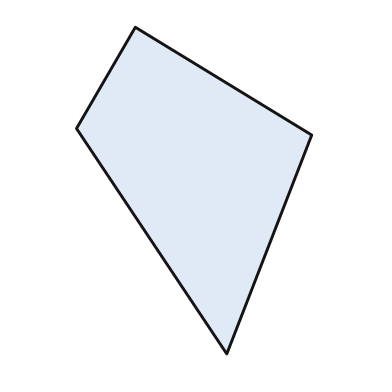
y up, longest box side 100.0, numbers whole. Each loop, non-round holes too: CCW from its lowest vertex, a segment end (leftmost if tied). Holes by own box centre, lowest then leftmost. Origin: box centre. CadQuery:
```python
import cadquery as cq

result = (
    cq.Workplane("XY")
    .moveTo(10.0, -50.0)
    .lineTo(36.0, 17.0)
    .lineTo(-18.0, 50.0)
    .lineTo(-36.0, 19.0)
    .close()
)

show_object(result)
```